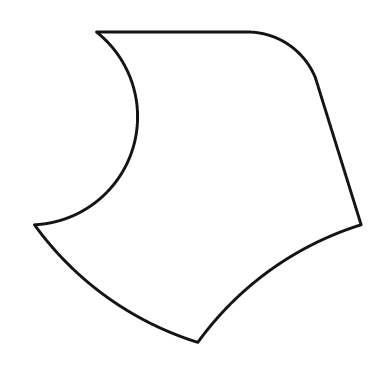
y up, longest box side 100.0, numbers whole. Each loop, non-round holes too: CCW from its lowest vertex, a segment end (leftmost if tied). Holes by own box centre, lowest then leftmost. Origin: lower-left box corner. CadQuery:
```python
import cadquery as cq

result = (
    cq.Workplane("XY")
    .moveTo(50.0, 0.0)
    .threePointArc((72.0, 22.0), (100.0, 36.0))
    .lineTo(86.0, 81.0)
    .threePointArc((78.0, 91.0), (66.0, 95.0))
    .lineTo(19.0, 95.0)
    .threePointArc((30.0, 59.0), (0.0, 36.0))
    .threePointArc((22.0, 14.0), (50.0, 0.0))
    .close()
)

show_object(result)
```